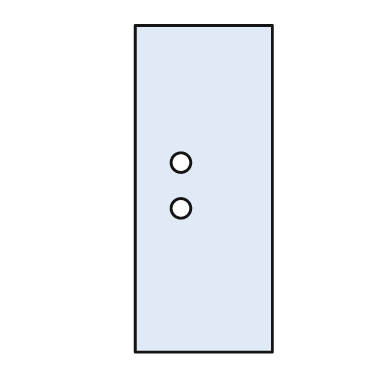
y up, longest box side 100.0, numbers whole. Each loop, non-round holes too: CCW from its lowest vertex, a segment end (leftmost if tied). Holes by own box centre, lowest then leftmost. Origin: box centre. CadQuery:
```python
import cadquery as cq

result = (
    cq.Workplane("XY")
    .moveTo(-21.0, -50.0)
    .lineTo(21.0, -50.0)
    .lineTo(21.0, 50.0)
    .lineTo(-21.0, 50.0)
    .close()
    .moveTo(-7.0, -6.0)
    .circle(3.0)
    .moveTo(-7.0, 8.0)
    .circle(3.0)
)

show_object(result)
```